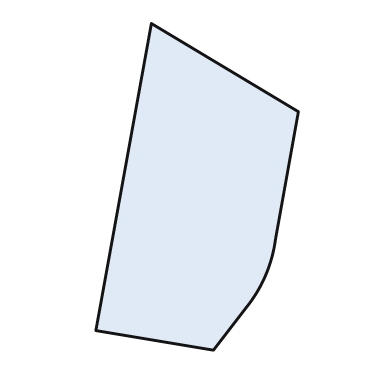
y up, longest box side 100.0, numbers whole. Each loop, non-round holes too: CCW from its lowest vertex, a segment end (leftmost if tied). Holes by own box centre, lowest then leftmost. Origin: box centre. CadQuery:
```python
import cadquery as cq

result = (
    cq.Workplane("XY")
    .moveTo(5.0, -50.0)
    .lineTo(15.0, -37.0)
    .threePointArc((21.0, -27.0), (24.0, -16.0))
    .lineTo(31.0, 23.0)
    .lineTo(-14.0, 50.0)
    .lineTo(-31.0, -44.0)
    .close()
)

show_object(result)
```